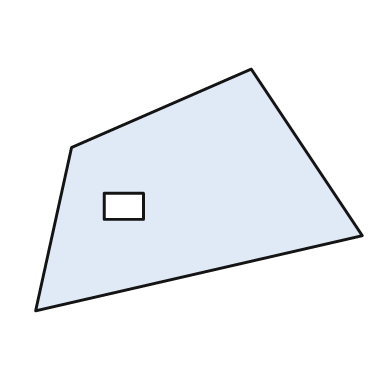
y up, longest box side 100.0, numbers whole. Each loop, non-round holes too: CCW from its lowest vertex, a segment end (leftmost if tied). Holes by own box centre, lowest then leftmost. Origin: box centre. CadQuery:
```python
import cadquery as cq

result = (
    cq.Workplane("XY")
    .moveTo(-50.0, -37.0)
    .lineTo(50.0, -14.0)
    .lineTo(16.0, 37.0)
    .lineTo(-39.0, 13.0)
    .close()
    .moveTo(-29.0, -9.0)
    .lineTo(-17.0, -9.0)
    .lineTo(-17.0, -1.0)
    .lineTo(-29.0, -1.0)
    .close()
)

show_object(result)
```